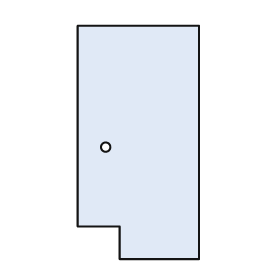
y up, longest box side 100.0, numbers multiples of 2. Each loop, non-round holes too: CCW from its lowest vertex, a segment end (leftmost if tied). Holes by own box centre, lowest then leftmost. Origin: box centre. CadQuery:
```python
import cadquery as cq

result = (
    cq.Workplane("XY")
    .moveTo(-8.0, -50.0)
    .lineTo(26.0, -50.0)
    .lineTo(26.0, 50.0)
    .lineTo(-26.0, 50.0)
    .lineTo(-26.0, -36.0)
    .lineTo(-8.0, -36.0)
    .close()
    .moveTo(-14.0, -2.0)
    .circle(2.0)
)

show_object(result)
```